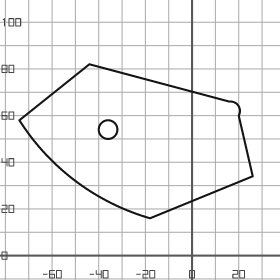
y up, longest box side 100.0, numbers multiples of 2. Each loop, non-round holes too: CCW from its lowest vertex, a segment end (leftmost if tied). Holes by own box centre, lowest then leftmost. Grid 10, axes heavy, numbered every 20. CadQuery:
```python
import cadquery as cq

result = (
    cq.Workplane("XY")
    .moveTo(-18.0, 16.0)
    .lineTo(26.0, 34.0)
    .lineTo(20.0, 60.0)
    .threePointArc((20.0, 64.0), (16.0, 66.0))
    .lineTo(-44.0, 82.0)
    .lineTo(-74.0, 58.0)
    .threePointArc((-50.0, 32.0), (-18.0, 16.0))
    .close()
    .moveTo(-36.0, 54.0)
    .circle(4.0)
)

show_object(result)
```